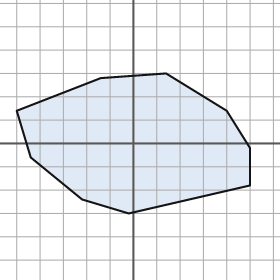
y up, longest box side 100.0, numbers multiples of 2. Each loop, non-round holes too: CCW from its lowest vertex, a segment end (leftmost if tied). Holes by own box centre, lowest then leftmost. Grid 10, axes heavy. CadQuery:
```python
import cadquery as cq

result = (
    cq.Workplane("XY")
    .moveTo(-2.0, -30.0)
    .lineTo(50.0, -18.0)
    .lineTo(50.0, -2.0)
    .lineTo(40.0, 14.0)
    .lineTo(14.0, 30.0)
    .lineTo(-14.0, 28.0)
    .lineTo(-50.0, 14.0)
    .lineTo(-44.0, -6.0)
    .lineTo(-22.0, -24.0)
    .close()
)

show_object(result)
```